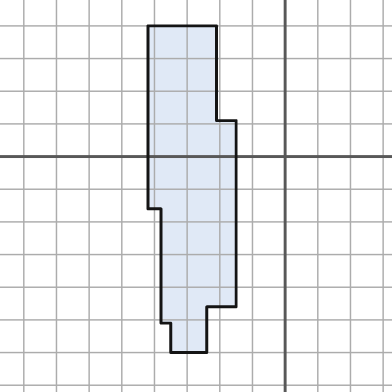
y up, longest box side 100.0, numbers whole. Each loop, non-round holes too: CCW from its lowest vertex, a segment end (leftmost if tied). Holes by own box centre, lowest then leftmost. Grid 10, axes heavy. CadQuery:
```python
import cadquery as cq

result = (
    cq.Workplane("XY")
    .moveTo(-35.0, -60.0)
    .lineTo(-24.0, -60.0)
    .lineTo(-24.0, -46.0)
    .lineTo(-15.0, -46.0)
    .lineTo(-15.0, 11.0)
    .lineTo(-21.0, 11.0)
    .lineTo(-21.0, 40.0)
    .lineTo(-42.0, 40.0)
    .lineTo(-42.0, -16.0)
    .lineTo(-38.0, -16.0)
    .lineTo(-38.0, -51.0)
    .lineTo(-35.0, -51.0)
    .close()
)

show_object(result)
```